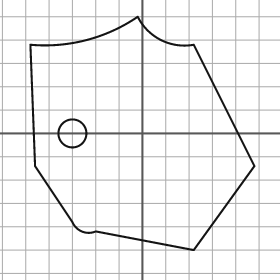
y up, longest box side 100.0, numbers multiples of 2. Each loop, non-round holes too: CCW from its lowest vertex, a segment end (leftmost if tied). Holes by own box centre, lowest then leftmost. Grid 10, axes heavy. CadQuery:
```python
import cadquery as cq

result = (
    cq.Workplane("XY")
    .moveTo(22.0, -50.0)
    .lineTo(48.0, -14.0)
    .lineTo(22.0, 38.0)
    .threePointArc((8.0, 40.0), (-2.0, 50.0))
    .threePointArc((-24.0, 40.0), (-48.0, 38.0))
    .lineTo(-46.0, -14.0)
    .lineTo(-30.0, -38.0)
    .threePointArc((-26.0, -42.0), (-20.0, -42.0))
    .close()
    .moveTo(-30.0, 0.0)
    .circle(6.0)
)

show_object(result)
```